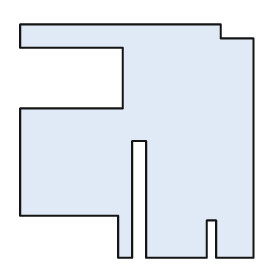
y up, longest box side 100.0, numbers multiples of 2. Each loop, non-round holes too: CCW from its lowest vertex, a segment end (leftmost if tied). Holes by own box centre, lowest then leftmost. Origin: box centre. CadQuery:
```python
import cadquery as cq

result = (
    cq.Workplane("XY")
    .moveTo(-8.0, -50.0)
    .lineTo(-2.0, -50.0)
    .lineTo(-2.0, 0.0)
    .lineTo(4.0, 0.0)
    .lineTo(4.0, -50.0)
    .lineTo(30.0, -50.0)
    .lineTo(30.0, -34.0)
    .lineTo(34.0, -34.0)
    .lineTo(34.0, -50.0)
    .lineTo(50.0, -50.0)
    .lineTo(50.0, 44.0)
    .lineTo(36.0, 44.0)
    .lineTo(36.0, 50.0)
    .lineTo(-50.0, 50.0)
    .lineTo(-50.0, 40.0)
    .lineTo(-6.0, 40.0)
    .lineTo(-6.0, 14.0)
    .lineTo(-50.0, 14.0)
    .lineTo(-50.0, -32.0)
    .lineTo(-8.0, -32.0)
    .close()
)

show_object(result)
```